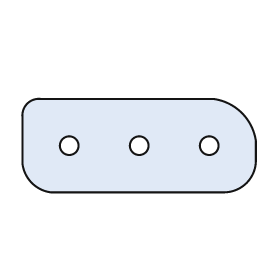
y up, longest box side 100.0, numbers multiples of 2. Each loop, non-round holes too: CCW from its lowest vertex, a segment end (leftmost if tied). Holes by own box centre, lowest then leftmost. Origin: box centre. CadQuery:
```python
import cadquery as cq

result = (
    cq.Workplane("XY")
    .moveTo(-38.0, -20.0)
    .lineTo(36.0, -20.0)
    .threePointArc((46.0, -16.0), (50.0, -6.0))
    .lineTo(50.0, 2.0)
    .threePointArc((44.0, 14.0), (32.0, 20.0))
    .lineTo(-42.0, 20.0)
    .threePointArc((-48.0, 18.0), (-50.0, 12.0))
    .lineTo(-50.0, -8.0)
    .threePointArc((-46.0, -16.0), (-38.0, -20.0))
    .close()
    .moveTo(-30.0, 0.0)
    .circle(4.0)
    .moveTo(0.0, 0.0)
    .circle(4.0)
    .moveTo(30.0, 0.0)
    .circle(4.0)
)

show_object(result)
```